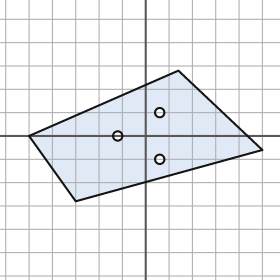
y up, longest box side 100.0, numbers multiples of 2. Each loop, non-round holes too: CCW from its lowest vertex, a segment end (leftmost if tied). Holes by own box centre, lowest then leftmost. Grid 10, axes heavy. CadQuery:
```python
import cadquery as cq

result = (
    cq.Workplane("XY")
    .moveTo(-30.0, -28.0)
    .lineTo(50.0, -6.0)
    .lineTo(14.0, 28.0)
    .lineTo(-50.0, 0.0)
    .close()
    .moveTo(6.0, -10.0)
    .circle(2.0)
    .moveTo(-12.0, 0.0)
    .circle(2.0)
    .moveTo(6.0, 10.0)
    .circle(2.0)
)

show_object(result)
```